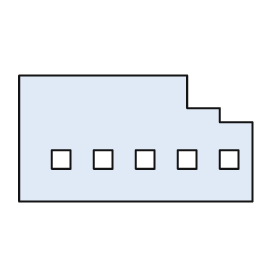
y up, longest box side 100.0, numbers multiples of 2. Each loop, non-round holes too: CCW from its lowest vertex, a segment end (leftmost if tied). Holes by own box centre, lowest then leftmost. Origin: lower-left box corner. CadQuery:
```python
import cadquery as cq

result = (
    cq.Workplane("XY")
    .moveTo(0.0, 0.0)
    .lineTo(100.0, 0.0)
    .lineTo(100.0, 34.0)
    .lineTo(86.0, 34.0)
    .lineTo(86.0, 40.0)
    .lineTo(72.0, 40.0)
    .lineTo(72.0, 54.0)
    .lineTo(0.0, 54.0)
    .close()
    .moveTo(14.0, 14.0)
    .lineTo(22.0, 14.0)
    .lineTo(22.0, 22.0)
    .lineTo(14.0, 22.0)
    .close()
    .moveTo(32.0, 14.0)
    .lineTo(40.0, 14.0)
    .lineTo(40.0, 22.0)
    .lineTo(32.0, 22.0)
    .close()
    .moveTo(50.0, 14.0)
    .lineTo(58.0, 14.0)
    .lineTo(58.0, 22.0)
    .lineTo(50.0, 22.0)
    .close()
    .moveTo(68.0, 14.0)
    .lineTo(76.0, 14.0)
    .lineTo(76.0, 22.0)
    .lineTo(68.0, 22.0)
    .close()
    .moveTo(86.0, 14.0)
    .lineTo(94.0, 14.0)
    .lineTo(94.0, 22.0)
    .lineTo(86.0, 22.0)
    .close()
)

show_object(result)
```